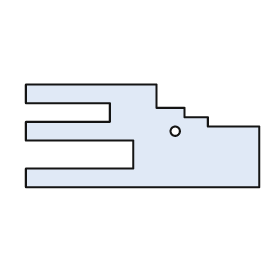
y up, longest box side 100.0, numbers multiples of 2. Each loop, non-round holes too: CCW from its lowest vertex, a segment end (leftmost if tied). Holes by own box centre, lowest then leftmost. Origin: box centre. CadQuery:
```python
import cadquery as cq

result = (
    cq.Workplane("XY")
    .moveTo(-50.0, -22.0)
    .lineTo(50.0, -22.0)
    .lineTo(50.0, 4.0)
    .lineTo(28.0, 4.0)
    .lineTo(28.0, 8.0)
    .lineTo(18.0, 8.0)
    .lineTo(18.0, 12.0)
    .lineTo(6.0, 12.0)
    .lineTo(6.0, 22.0)
    .lineTo(-50.0, 22.0)
    .lineTo(-50.0, 14.0)
    .lineTo(-14.0, 14.0)
    .lineTo(-14.0, 6.0)
    .lineTo(-50.0, 6.0)
    .lineTo(-50.0, -2.0)
    .lineTo(-4.0, -2.0)
    .lineTo(-4.0, -14.0)
    .lineTo(-50.0, -14.0)
    .close()
    .moveTo(14.0, 2.0)
    .circle(2.0)
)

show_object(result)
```